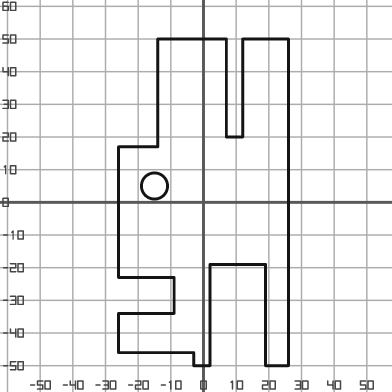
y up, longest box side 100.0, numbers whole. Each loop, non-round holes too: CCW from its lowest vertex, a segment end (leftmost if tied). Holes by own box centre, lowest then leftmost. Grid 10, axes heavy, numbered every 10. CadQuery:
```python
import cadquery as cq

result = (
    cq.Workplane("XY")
    .moveTo(-3.0, -50.0)
    .lineTo(2.0, -50.0)
    .lineTo(2.0, -19.0)
    .lineTo(19.0, -19.0)
    .lineTo(19.0, -50.0)
    .lineTo(26.0, -50.0)
    .lineTo(26.0, 50.0)
    .lineTo(12.0, 50.0)
    .lineTo(12.0, 20.0)
    .lineTo(7.0, 20.0)
    .lineTo(7.0, 50.0)
    .lineTo(-14.0, 50.0)
    .lineTo(-14.0, 17.0)
    .lineTo(-26.0, 17.0)
    .lineTo(-26.0, -23.0)
    .lineTo(-9.0, -23.0)
    .lineTo(-9.0, -34.0)
    .lineTo(-26.0, -34.0)
    .lineTo(-26.0, -46.0)
    .lineTo(-3.0, -46.0)
    .close()
    .moveTo(-15.0, 5.0)
    .circle(4.0)
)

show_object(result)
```